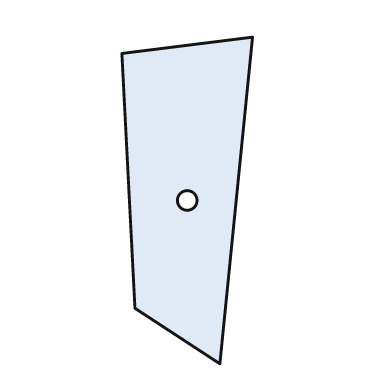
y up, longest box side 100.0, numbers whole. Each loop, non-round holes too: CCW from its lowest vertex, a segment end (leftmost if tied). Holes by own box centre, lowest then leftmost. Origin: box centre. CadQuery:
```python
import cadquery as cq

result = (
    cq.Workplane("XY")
    .moveTo(10.0, -50.0)
    .lineTo(20.0, 50.0)
    .lineTo(-20.0, 45.0)
    .lineTo(-16.0, -33.0)
    .close()
    .moveTo(0.0, 0.0)
    .circle(3.0)
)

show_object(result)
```